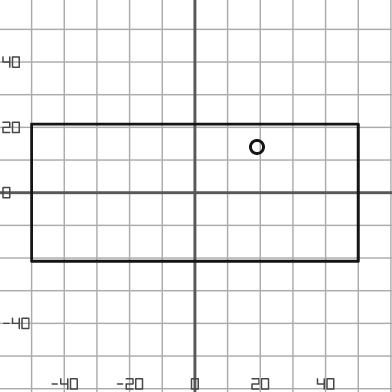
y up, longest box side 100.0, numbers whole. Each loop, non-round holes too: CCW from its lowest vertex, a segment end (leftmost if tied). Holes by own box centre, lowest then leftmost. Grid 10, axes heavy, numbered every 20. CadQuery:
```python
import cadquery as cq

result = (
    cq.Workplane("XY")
    .moveTo(-50.0, -21.0)
    .lineTo(50.0, -21.0)
    .lineTo(50.0, 21.0)
    .lineTo(-50.0, 21.0)
    .close()
    .moveTo(19.0, 14.0)
    .circle(2.0)
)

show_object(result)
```